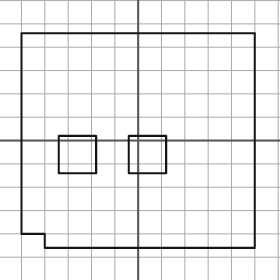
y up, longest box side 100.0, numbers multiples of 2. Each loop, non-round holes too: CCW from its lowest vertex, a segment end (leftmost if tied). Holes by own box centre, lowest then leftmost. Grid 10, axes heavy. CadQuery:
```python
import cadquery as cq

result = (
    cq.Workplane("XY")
    .moveTo(-40.0, -46.0)
    .lineTo(50.0, -46.0)
    .lineTo(50.0, 46.0)
    .lineTo(-50.0, 46.0)
    .lineTo(-50.0, -40.0)
    .lineTo(-40.0, -40.0)
    .close()
    .moveTo(-34.0, -14.0)
    .lineTo(-18.0, -14.0)
    .lineTo(-18.0, 2.0)
    .lineTo(-34.0, 2.0)
    .close()
    .moveTo(-4.0, -14.0)
    .lineTo(12.0, -14.0)
    .lineTo(12.0, 2.0)
    .lineTo(-4.0, 2.0)
    .close()
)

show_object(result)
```